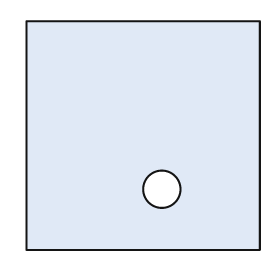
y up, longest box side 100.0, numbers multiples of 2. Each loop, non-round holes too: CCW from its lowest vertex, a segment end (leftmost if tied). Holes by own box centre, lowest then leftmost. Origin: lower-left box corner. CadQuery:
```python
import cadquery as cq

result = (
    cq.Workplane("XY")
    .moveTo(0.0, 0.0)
    .lineTo(100.0, 0.0)
    .lineTo(100.0, 98.0)
    .lineTo(0.0, 98.0)
    .close()
    .moveTo(58.0, 26.0)
    .circle(8.0)
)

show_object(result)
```